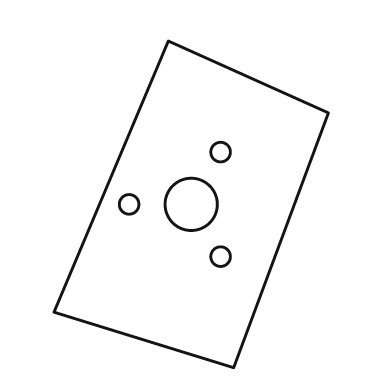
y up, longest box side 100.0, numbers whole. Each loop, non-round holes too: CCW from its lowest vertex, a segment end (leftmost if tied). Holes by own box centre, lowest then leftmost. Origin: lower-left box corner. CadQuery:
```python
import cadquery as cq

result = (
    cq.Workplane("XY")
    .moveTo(55.0, 0.0)
    .lineTo(84.0, 78.0)
    .lineTo(35.0, 100.0)
    .lineTo(0.0, 17.0)
    .close()
    .moveTo(51.0, 34.0)
    .circle(3.0)
    .moveTo(23.0, 50.0)
    .circle(3.0)
    .moveTo(42.0, 50.0)
    .circle(8.0)
    .moveTo(51.0, 66.0)
    .circle(3.0)
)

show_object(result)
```